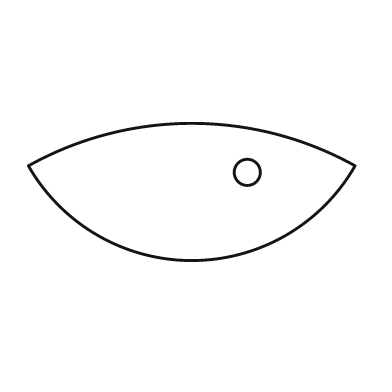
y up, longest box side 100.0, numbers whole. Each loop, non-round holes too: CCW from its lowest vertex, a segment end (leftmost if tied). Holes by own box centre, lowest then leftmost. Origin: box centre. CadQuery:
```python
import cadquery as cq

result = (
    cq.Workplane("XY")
    .moveTo(-50.0, 8.0)
    .threePointArc((0.0, -21.0), (50.0, 8.0))
    .threePointArc((0.0, 21.0), (-50.0, 8.0))
    .close()
    .moveTo(17.0, 6.0)
    .circle(4.0)
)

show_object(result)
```